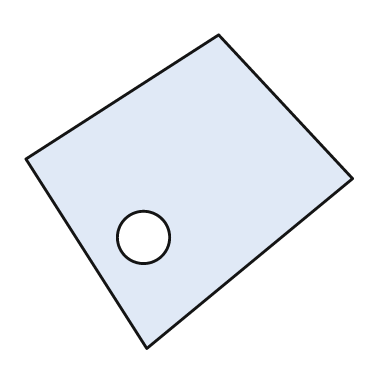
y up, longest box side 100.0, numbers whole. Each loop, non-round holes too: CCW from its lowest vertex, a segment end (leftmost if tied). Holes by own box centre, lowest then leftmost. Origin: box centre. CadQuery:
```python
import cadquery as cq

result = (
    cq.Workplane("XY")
    .moveTo(-13.0, -48.0)
    .lineTo(50.0, 4.0)
    .lineTo(9.0, 48.0)
    .lineTo(-50.0, 10.0)
    .close()
    .moveTo(-14.0, -14.0)
    .circle(8.0)
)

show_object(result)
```